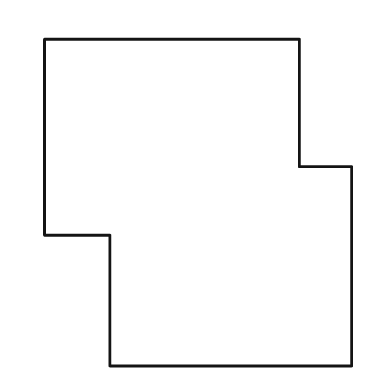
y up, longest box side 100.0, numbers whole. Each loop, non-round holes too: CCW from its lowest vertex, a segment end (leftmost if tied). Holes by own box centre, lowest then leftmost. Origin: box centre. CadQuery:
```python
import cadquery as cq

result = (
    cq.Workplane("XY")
    .moveTo(-27.0, -50.0)
    .lineTo(47.0, -50.0)
    .lineTo(47.0, 11.0)
    .lineTo(31.0, 11.0)
    .lineTo(31.0, 50.0)
    .lineTo(-47.0, 50.0)
    .lineTo(-47.0, -10.0)
    .lineTo(-27.0, -10.0)
    .close()
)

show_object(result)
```